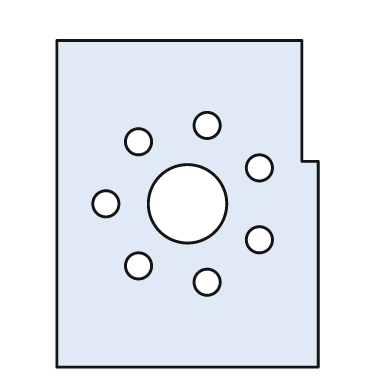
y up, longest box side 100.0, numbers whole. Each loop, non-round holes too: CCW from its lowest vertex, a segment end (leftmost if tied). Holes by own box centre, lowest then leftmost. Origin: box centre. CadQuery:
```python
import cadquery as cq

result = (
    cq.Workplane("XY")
    .moveTo(-40.0, -50.0)
    .lineTo(40.0, -50.0)
    .lineTo(40.0, 13.0)
    .lineTo(35.0, 13.0)
    .lineTo(35.0, 50.0)
    .lineTo(-40.0, 50.0)
    .close()
    .moveTo(6.0, -24.0)
    .circle(4.0)
    .moveTo(-15.0, -19.0)
    .circle(4.0)
    .moveTo(22.0, -11.0)
    .circle(4.0)
    .moveTo(-25.0, 0.0)
    .circle(4.0)
    .moveTo(0.0, 0.0)
    .circle(12.0)
    .moveTo(22.0, 11.0)
    .circle(4.0)
    .moveTo(-15.0, 19.0)
    .circle(4.0)
    .moveTo(6.0, 24.0)
    .circle(4.0)
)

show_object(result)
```